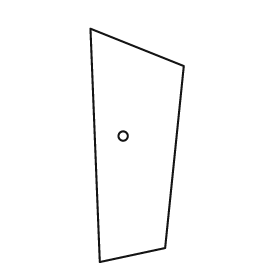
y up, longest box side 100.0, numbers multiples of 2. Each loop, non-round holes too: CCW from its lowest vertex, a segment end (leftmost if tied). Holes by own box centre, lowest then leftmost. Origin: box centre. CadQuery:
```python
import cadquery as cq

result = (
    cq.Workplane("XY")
    .moveTo(-16.0, -50.0)
    .lineTo(12.0, -44.0)
    .lineTo(20.0, 34.0)
    .lineTo(-20.0, 50.0)
    .close()
    .moveTo(-6.0, 4.0)
    .circle(2.0)
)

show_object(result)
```